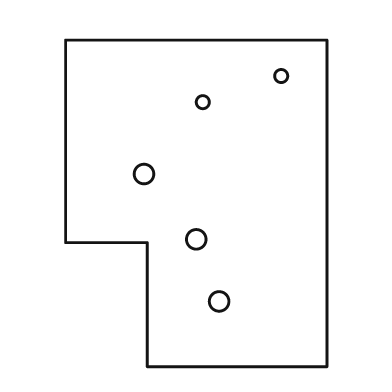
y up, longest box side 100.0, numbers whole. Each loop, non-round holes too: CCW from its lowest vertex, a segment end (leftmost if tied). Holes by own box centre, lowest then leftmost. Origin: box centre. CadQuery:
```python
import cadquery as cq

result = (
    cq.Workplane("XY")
    .moveTo(-15.0, -50.0)
    .lineTo(40.0, -50.0)
    .lineTo(40.0, 50.0)
    .lineTo(-40.0, 50.0)
    .lineTo(-40.0, -12.0)
    .lineTo(-15.0, -12.0)
    .close()
    .moveTo(7.0, -30.0)
    .circle(3.0)
    .moveTo(0.0, -11.0)
    .circle(3.0)
    .moveTo(-16.0, 9.0)
    .circle(3.0)
    .moveTo(2.0, 31.0)
    .circle(2.0)
    .moveTo(26.0, 39.0)
    .circle(2.0)
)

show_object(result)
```